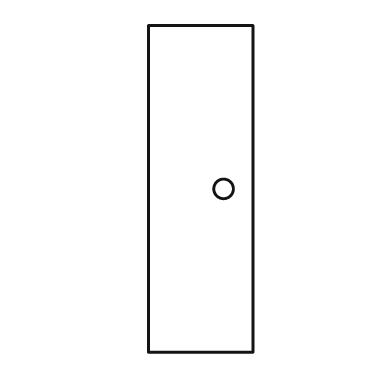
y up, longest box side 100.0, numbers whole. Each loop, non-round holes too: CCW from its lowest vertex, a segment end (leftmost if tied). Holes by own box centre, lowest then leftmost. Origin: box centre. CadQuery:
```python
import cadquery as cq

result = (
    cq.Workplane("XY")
    .moveTo(-16.0, -50.0)
    .lineTo(16.0, -50.0)
    .lineTo(16.0, 50.0)
    .lineTo(-16.0, 50.0)
    .close()
    .moveTo(7.0, 0.0)
    .circle(3.0)
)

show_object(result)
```